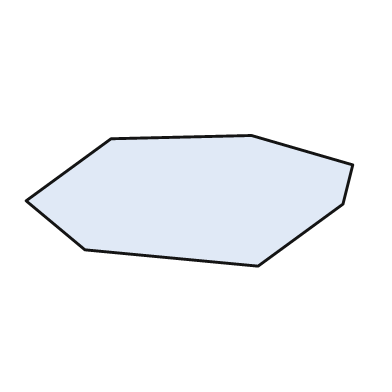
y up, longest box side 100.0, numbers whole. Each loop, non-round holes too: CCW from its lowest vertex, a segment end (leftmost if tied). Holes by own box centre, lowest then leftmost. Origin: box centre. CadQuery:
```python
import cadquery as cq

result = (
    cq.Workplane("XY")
    .moveTo(21.0, -20.0)
    .lineTo(47.0, -1.0)
    .lineTo(50.0, 11.0)
    .lineTo(19.0, 20.0)
    .lineTo(-24.0, 19.0)
    .lineTo(-50.0, 0.0)
    .lineTo(-32.0, -15.0)
    .close()
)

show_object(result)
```